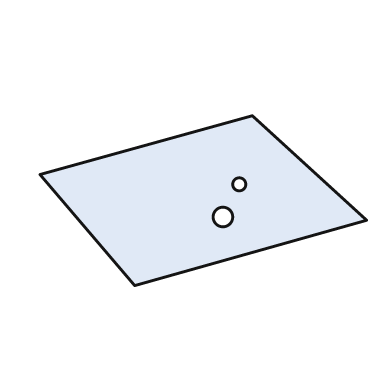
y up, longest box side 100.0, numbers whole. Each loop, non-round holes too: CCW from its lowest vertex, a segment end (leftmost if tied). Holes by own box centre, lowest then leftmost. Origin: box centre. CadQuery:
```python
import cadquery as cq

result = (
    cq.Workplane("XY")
    .moveTo(-21.0, -26.0)
    .lineTo(50.0, -6.0)
    .lineTo(15.0, 26.0)
    .lineTo(-50.0, 8.0)
    .close()
    .moveTo(6.0, -5.0)
    .circle(3.0)
    .moveTo(11.0, 5.0)
    .circle(2.0)
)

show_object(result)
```